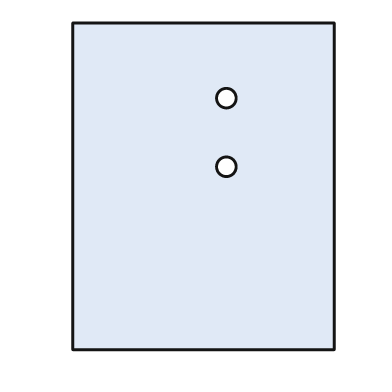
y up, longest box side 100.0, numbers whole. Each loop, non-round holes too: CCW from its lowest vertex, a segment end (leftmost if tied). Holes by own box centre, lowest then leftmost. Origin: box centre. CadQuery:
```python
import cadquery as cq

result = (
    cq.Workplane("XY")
    .moveTo(-40.0, -50.0)
    .lineTo(40.0, -50.0)
    .lineTo(40.0, 50.0)
    .lineTo(-40.0, 50.0)
    .close()
    .moveTo(7.0, 6.0)
    .circle(3.0)
    .moveTo(7.0, 27.0)
    .circle(3.0)
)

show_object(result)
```